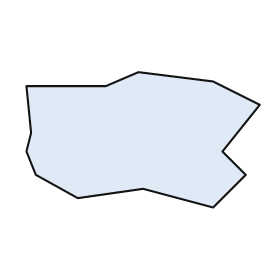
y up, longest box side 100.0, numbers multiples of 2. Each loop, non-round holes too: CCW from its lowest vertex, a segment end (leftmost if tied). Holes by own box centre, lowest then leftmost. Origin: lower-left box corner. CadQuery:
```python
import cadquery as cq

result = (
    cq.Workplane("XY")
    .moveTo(80.0, 0.0)
    .lineTo(94.0, 14.0)
    .lineTo(84.0, 24.0)
    .lineTo(100.0, 44.0)
    .lineTo(80.0, 54.0)
    .lineTo(48.0, 58.0)
    .lineTo(34.0, 52.0)
    .lineTo(0.0, 52.0)
    .lineTo(2.0, 32.0)
    .lineTo(0.0, 24.0)
    .lineTo(4.0, 14.0)
    .lineTo(22.0, 4.0)
    .lineTo(50.0, 8.0)
    .close()
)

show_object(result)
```